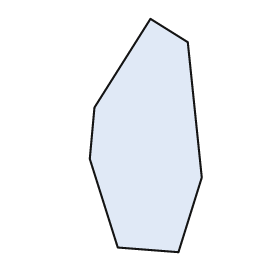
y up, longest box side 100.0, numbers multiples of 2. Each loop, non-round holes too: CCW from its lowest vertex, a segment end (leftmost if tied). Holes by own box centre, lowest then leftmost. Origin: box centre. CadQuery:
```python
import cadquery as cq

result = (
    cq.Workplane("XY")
    .moveTo(14.0, -50.0)
    .lineTo(24.0, -18.0)
    .lineTo(18.0, 40.0)
    .lineTo(2.0, 50.0)
    .lineTo(-22.0, 12.0)
    .lineTo(-24.0, -10.0)
    .lineTo(-12.0, -48.0)
    .close()
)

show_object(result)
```